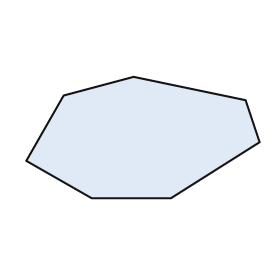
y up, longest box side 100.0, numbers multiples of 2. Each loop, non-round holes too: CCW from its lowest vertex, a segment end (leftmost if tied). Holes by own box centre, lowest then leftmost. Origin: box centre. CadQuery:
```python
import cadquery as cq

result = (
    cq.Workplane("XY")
    .moveTo(-22.0, -26.0)
    .lineTo(12.0, -26.0)
    .lineTo(50.0, -2.0)
    .lineTo(44.0, 16.0)
    .lineTo(-4.0, 26.0)
    .lineTo(-34.0, 18.0)
    .lineTo(-50.0, -10.0)
    .close()
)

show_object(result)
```